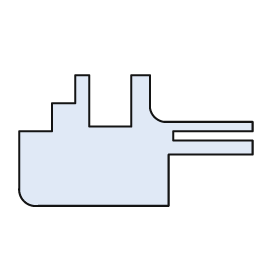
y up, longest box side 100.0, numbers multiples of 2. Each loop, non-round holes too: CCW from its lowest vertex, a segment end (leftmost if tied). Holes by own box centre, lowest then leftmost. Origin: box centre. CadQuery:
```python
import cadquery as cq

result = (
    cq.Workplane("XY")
    .moveTo(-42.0, -28.0)
    .lineTo(14.0, -28.0)
    .lineTo(14.0, -6.0)
    .lineTo(50.0, -6.0)
    .lineTo(50.0, 0.0)
    .lineTo(16.0, 0.0)
    .lineTo(16.0, 4.0)
    .lineTo(50.0, 4.0)
    .lineTo(50.0, 8.0)
    .lineTo(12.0, 8.0)
    .threePointArc((8.0, 10.0), (6.0, 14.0))
    .lineTo(6.0, 28.0)
    .lineTo(-2.0, 28.0)
    .lineTo(-2.0, 6.0)
    .lineTo(-20.0, 6.0)
    .lineTo(-20.0, 28.0)
    .lineTo(-26.0, 28.0)
    .lineTo(-26.0, 16.0)
    .lineTo(-36.0, 16.0)
    .lineTo(-36.0, 4.0)
    .lineTo(-50.0, 4.0)
    .lineTo(-50.0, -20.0)
    .threePointArc((-48.0, -26.0), (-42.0, -28.0))
    .close()
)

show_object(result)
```